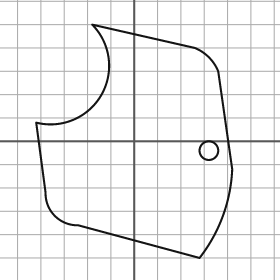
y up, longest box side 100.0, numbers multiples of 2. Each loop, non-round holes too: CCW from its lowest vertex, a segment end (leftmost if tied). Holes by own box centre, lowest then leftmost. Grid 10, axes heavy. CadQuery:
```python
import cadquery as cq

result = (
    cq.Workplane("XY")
    .moveTo(28.0, -50.0)
    .threePointArc((38.0, -32.0), (42.0, -12.0))
    .lineTo(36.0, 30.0)
    .threePointArc((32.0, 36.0), (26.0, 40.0))
    .lineTo(-18.0, 50.0)
    .threePointArc((-14.0, 20.0), (-42.0, 8.0))
    .lineTo(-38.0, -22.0)
    .threePointArc((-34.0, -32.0), (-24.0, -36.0))
    .close()
    .moveTo(32.0, -4.0)
    .circle(4.0)
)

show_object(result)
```